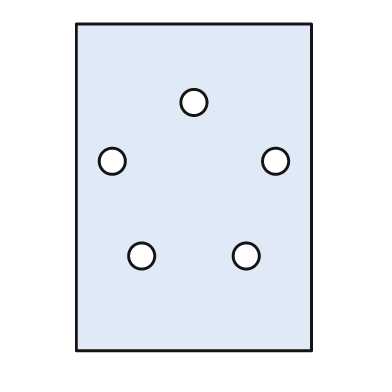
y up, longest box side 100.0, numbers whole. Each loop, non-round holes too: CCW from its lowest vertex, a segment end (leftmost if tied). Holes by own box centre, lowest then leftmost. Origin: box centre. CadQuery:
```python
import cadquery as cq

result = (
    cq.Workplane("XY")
    .moveTo(-36.0, -50.0)
    .lineTo(36.0, -50.0)
    .lineTo(36.0, 50.0)
    .lineTo(-36.0, 50.0)
    .close()
    .moveTo(-16.0, -21.0)
    .circle(4.0)
    .moveTo(16.0, -21.0)
    .circle(4.0)
    .moveTo(-25.0, 8.0)
    .circle(4.0)
    .moveTo(25.0, 8.0)
    .circle(4.0)
    .moveTo(0.0, 26.0)
    .circle(4.0)
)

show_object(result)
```